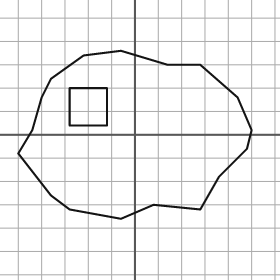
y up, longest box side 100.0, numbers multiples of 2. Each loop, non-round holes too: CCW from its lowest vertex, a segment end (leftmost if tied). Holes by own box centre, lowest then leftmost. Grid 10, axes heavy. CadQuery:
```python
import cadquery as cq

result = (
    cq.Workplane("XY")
    .moveTo(-6.0, -36.0)
    .lineTo(8.0, -30.0)
    .lineTo(28.0, -32.0)
    .lineTo(36.0, -18.0)
    .lineTo(48.0, -6.0)
    .lineTo(50.0, 2.0)
    .lineTo(44.0, 16.0)
    .lineTo(28.0, 30.0)
    .lineTo(14.0, 30.0)
    .lineTo(-6.0, 36.0)
    .lineTo(-22.0, 34.0)
    .lineTo(-36.0, 24.0)
    .lineTo(-40.0, 16.0)
    .lineTo(-44.0, 2.0)
    .lineTo(-50.0, -8.0)
    .lineTo(-36.0, -26.0)
    .lineTo(-28.0, -32.0)
    .close()
    .moveTo(-28.0, 4.0)
    .lineTo(-12.0, 4.0)
    .lineTo(-12.0, 20.0)
    .lineTo(-28.0, 20.0)
    .close()
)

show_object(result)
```